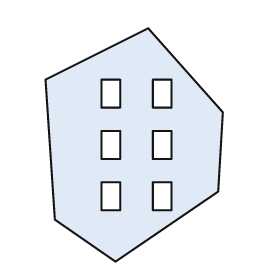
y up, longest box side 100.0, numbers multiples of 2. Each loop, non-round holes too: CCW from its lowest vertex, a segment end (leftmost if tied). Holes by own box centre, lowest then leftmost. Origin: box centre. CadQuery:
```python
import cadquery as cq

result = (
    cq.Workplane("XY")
    .moveTo(-8.0, -50.0)
    .lineTo(36.0, -20.0)
    .lineTo(38.0, 14.0)
    .lineTo(6.0, 50.0)
    .lineTo(-38.0, 28.0)
    .lineTo(-34.0, -32.0)
    .close()
    .moveTo(-14.0, -28.0)
    .lineTo(-6.0, -28.0)
    .lineTo(-6.0, -16.0)
    .lineTo(-14.0, -16.0)
    .close()
    .moveTo(8.0, -28.0)
    .lineTo(16.0, -28.0)
    .lineTo(16.0, -16.0)
    .lineTo(8.0, -16.0)
    .close()
    .moveTo(-14.0, -6.0)
    .lineTo(-6.0, -6.0)
    .lineTo(-6.0, 6.0)
    .lineTo(-14.0, 6.0)
    .close()
    .moveTo(8.0, -6.0)
    .lineTo(16.0, -6.0)
    .lineTo(16.0, 6.0)
    .lineTo(8.0, 6.0)
    .close()
    .moveTo(-14.0, 16.0)
    .lineTo(-6.0, 16.0)
    .lineTo(-6.0, 28.0)
    .lineTo(-14.0, 28.0)
    .close()
    .moveTo(8.0, 16.0)
    .lineTo(16.0, 16.0)
    .lineTo(16.0, 28.0)
    .lineTo(8.0, 28.0)
    .close()
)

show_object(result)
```